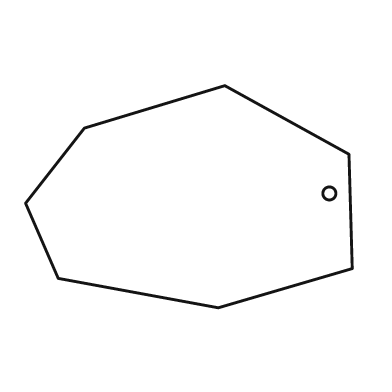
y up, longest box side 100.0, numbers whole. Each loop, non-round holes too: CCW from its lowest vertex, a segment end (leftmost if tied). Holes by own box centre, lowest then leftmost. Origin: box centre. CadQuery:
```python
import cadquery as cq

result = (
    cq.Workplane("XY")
    .moveTo(9.0, -34.0)
    .lineTo(50.0, -22.0)
    .lineTo(49.0, 13.0)
    .lineTo(11.0, 34.0)
    .lineTo(-32.0, 21.0)
    .lineTo(-50.0, -2.0)
    .lineTo(-40.0, -25.0)
    .close()
    .moveTo(43.0, 1.0)
    .circle(2.0)
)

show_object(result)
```